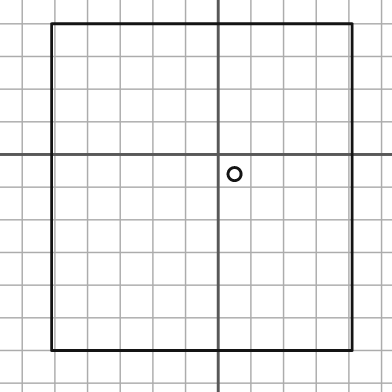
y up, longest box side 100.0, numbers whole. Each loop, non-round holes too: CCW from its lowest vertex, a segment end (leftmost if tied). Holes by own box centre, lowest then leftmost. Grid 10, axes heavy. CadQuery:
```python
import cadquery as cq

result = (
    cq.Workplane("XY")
    .moveTo(-51.0, -60.0)
    .lineTo(41.0, -60.0)
    .lineTo(41.0, 40.0)
    .lineTo(-51.0, 40.0)
    .close()
    .moveTo(5.0, -6.0)
    .circle(2.0)
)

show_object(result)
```